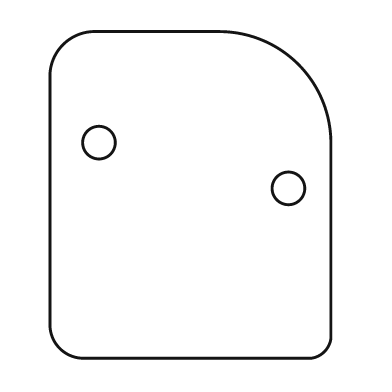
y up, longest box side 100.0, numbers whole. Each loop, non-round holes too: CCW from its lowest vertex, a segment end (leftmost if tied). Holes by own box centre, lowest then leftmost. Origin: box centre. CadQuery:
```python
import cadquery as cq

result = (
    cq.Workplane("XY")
    .moveTo(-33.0, -50.0)
    .lineTo(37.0, -50.0)
    .threePointArc((41.0, -48.0), (43.0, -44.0))
    .lineTo(43.0, 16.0)
    .threePointArc((33.0, 40.0), (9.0, 50.0))
    .lineTo(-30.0, 50.0)
    .threePointArc((-39.0, 46.0), (-43.0, 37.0))
    .lineTo(-43.0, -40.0)
    .threePointArc((-40.0, -47.0), (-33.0, -50.0))
    .close()
    .moveTo(30.0, 2.0)
    .circle(5.0)
    .moveTo(-28.0, 16.0)
    .circle(5.0)
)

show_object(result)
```